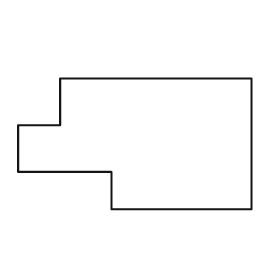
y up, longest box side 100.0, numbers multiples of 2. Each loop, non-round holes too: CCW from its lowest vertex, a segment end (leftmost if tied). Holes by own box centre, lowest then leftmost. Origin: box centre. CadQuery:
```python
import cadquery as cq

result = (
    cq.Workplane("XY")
    .moveTo(-10.0, -28.0)
    .lineTo(50.0, -28.0)
    .lineTo(50.0, 28.0)
    .lineTo(-32.0, 28.0)
    .lineTo(-32.0, 8.0)
    .lineTo(-50.0, 8.0)
    .lineTo(-50.0, -12.0)
    .lineTo(-10.0, -12.0)
    .close()
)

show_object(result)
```